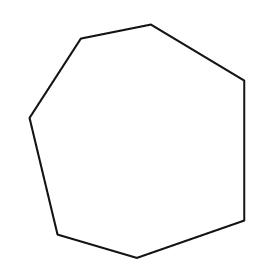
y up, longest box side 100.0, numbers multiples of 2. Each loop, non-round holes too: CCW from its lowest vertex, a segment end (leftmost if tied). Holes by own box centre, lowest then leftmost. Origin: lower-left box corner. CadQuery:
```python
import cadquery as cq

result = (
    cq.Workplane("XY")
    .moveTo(46.0, 0.0)
    .lineTo(92.0, 16.0)
    .lineTo(92.0, 76.0)
    .lineTo(52.0, 100.0)
    .lineTo(22.0, 94.0)
    .lineTo(0.0, 60.0)
    .lineTo(12.0, 10.0)
    .close()
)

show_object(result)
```